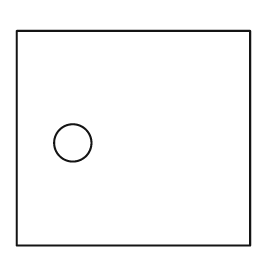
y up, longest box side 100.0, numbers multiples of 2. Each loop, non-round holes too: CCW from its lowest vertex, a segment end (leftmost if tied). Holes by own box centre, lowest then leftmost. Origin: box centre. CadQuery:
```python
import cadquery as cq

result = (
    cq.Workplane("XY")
    .moveTo(-50.0, -46.0)
    .lineTo(50.0, -46.0)
    .lineTo(50.0, 46.0)
    .lineTo(-50.0, 46.0)
    .close()
    .moveTo(-26.0, -2.0)
    .circle(8.0)
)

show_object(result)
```